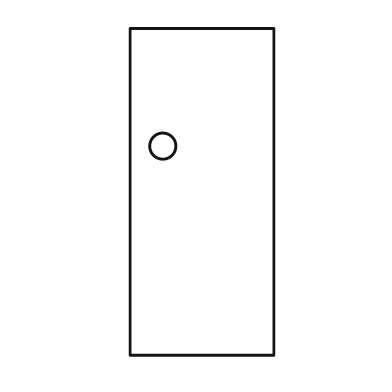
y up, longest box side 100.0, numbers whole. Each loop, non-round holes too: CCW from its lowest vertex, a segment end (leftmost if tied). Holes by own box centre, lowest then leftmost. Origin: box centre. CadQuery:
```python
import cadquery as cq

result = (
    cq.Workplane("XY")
    .moveTo(-22.0, -50.0)
    .lineTo(22.0, -50.0)
    .lineTo(22.0, 50.0)
    .lineTo(-22.0, 50.0)
    .close()
    .moveTo(-12.0, 14.0)
    .circle(4.0)
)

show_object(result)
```